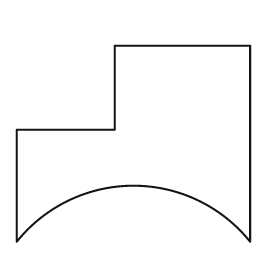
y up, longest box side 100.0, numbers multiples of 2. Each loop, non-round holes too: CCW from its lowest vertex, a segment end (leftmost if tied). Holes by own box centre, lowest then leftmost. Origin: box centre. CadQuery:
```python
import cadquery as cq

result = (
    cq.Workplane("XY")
    .moveTo(-50.0, -42.0)
    .threePointArc((0.0, -18.0), (50.0, -42.0))
    .lineTo(50.0, 42.0)
    .lineTo(-8.0, 42.0)
    .lineTo(-8.0, 6.0)
    .lineTo(-50.0, 6.0)
    .close()
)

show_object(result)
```